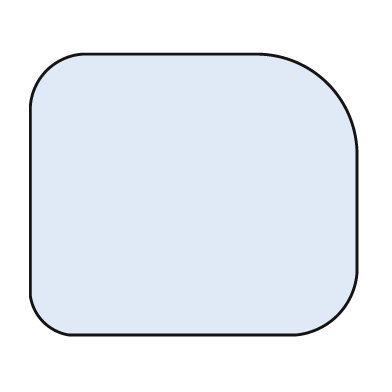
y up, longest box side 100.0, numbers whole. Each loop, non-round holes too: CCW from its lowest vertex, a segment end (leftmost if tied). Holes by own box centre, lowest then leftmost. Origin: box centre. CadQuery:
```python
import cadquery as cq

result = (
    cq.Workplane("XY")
    .moveTo(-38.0, -43.0)
    .lineTo(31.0, -43.0)
    .threePointArc((44.0, -37.0), (50.0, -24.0))
    .lineTo(50.0, 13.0)
    .threePointArc((41.0, 34.0), (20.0, 43.0))
    .lineTo(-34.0, 43.0)
    .threePointArc((-45.0, 38.0), (-50.0, 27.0))
    .lineTo(-50.0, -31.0)
    .threePointArc((-46.0, -39.0), (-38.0, -43.0))
    .close()
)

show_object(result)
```